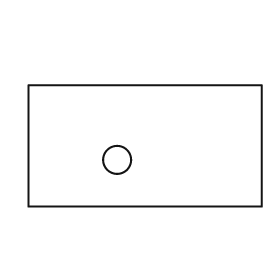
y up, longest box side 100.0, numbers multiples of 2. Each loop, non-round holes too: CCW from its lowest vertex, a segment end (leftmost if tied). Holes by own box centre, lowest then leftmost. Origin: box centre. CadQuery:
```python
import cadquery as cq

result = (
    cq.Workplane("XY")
    .moveTo(-50.0, -26.0)
    .lineTo(50.0, -26.0)
    .lineTo(50.0, 26.0)
    .lineTo(-50.0, 26.0)
    .close()
    .moveTo(-12.0, -6.0)
    .circle(6.0)
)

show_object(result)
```